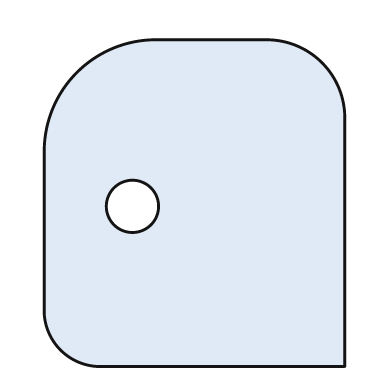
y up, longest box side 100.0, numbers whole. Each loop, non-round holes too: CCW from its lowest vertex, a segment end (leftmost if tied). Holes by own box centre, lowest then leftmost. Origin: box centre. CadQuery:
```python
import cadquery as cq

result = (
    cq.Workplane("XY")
    .moveTo(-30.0, -50.0)
    .lineTo(46.0, -50.0)
    .lineTo(46.0, 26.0)
    .threePointArc((39.0, 43.0), (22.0, 50.0))
    .lineTo(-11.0, 50.0)
    .threePointArc((-36.0, 40.0), (-46.0, 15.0))
    .lineTo(-46.0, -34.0)
    .threePointArc((-41.0, -45.0), (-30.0, -50.0))
    .close()
    .moveTo(-19.0, -1.0)
    .circle(8.0)
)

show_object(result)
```